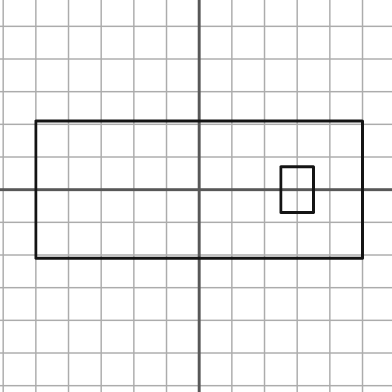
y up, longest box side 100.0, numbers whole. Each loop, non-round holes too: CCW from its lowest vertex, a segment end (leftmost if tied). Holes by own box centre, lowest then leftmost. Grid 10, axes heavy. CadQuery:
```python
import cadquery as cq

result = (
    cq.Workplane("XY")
    .moveTo(-50.0, -21.0)
    .lineTo(50.0, -21.0)
    .lineTo(50.0, 21.0)
    .lineTo(-50.0, 21.0)
    .close()
    .moveTo(25.0, -7.0)
    .lineTo(35.0, -7.0)
    .lineTo(35.0, 7.0)
    .lineTo(25.0, 7.0)
    .close()
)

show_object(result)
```